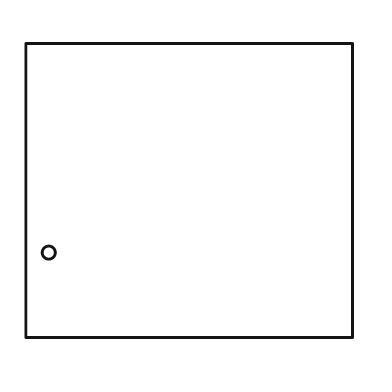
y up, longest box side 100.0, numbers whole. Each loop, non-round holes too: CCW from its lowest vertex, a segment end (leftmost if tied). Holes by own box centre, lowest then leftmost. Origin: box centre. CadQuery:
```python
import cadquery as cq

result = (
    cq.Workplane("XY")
    .moveTo(-50.0, -45.0)
    .lineTo(50.0, -45.0)
    .lineTo(50.0, 45.0)
    .lineTo(-50.0, 45.0)
    .close()
    .moveTo(-43.0, -19.0)
    .circle(2.0)
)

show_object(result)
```